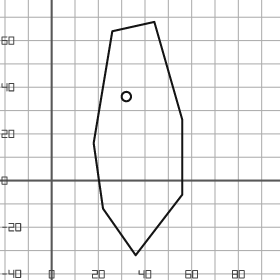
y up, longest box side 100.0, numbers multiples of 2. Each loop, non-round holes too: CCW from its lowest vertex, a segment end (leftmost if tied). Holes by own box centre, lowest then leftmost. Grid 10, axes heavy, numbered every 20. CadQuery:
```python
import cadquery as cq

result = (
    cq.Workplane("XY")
    .moveTo(36.0, -32.0)
    .lineTo(56.0, -6.0)
    .lineTo(56.0, 26.0)
    .lineTo(44.0, 68.0)
    .lineTo(26.0, 64.0)
    .lineTo(18.0, 16.0)
    .lineTo(22.0, -12.0)
    .close()
    .moveTo(32.0, 36.0)
    .circle(2.0)
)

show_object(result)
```